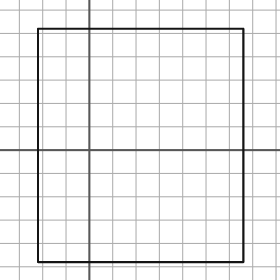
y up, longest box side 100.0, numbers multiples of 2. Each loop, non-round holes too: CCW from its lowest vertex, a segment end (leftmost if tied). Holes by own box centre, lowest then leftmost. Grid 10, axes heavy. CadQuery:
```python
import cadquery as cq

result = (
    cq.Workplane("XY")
    .moveTo(-22.0, -48.0)
    .lineTo(66.0, -48.0)
    .lineTo(66.0, 52.0)
    .lineTo(-22.0, 52.0)
    .close()
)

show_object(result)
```